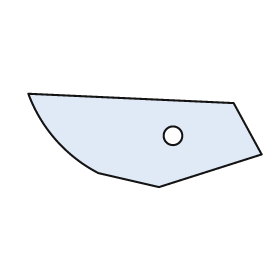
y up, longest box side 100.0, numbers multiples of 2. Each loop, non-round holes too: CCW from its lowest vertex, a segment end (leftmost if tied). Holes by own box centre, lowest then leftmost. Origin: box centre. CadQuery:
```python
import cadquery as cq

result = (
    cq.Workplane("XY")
    .moveTo(6.0, -20.0)
    .lineTo(50.0, -6.0)
    .lineTo(38.0, 16.0)
    .lineTo(-50.0, 20.0)
    .threePointArc((-38.0, 0.0), (-20.0, -14.0))
    .close()
    .moveTo(12.0, 2.0)
    .circle(4.0)
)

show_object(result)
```